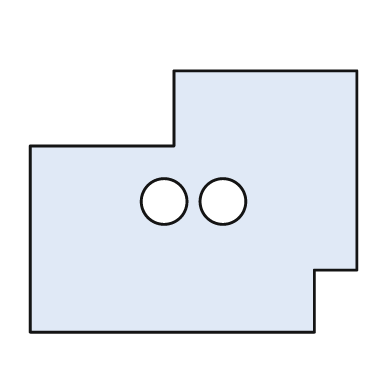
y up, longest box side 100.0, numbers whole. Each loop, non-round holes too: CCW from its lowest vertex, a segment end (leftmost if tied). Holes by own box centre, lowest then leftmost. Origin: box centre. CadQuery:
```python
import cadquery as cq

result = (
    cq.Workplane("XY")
    .moveTo(-50.0, -40.0)
    .lineTo(37.0, -40.0)
    .lineTo(37.0, -21.0)
    .lineTo(50.0, -21.0)
    .lineTo(50.0, 40.0)
    .lineTo(-6.0, 40.0)
    .lineTo(-6.0, 17.0)
    .lineTo(-50.0, 17.0)
    .close()
    .moveTo(-9.0, 0.0)
    .circle(7.0)
    .moveTo(9.0, 0.0)
    .circle(7.0)
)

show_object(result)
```